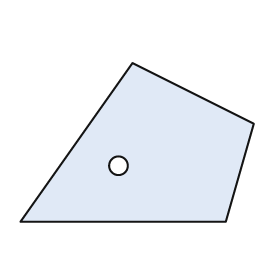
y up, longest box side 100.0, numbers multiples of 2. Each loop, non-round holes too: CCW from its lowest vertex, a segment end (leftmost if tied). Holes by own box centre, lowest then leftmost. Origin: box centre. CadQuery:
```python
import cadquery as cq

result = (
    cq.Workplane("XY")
    .moveTo(-50.0, -34.0)
    .lineTo(38.0, -34.0)
    .lineTo(50.0, 8.0)
    .lineTo(-2.0, 34.0)
    .close()
    .moveTo(-8.0, -10.0)
    .circle(4.0)
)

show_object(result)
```